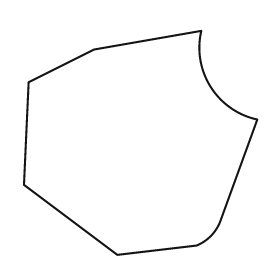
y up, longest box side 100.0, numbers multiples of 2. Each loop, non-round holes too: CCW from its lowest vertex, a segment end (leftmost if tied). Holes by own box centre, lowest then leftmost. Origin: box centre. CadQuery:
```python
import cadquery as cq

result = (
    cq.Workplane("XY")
    .moveTo(-10.0, -48.0)
    .lineTo(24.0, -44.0)
    .threePointArc((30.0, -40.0), (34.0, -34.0))
    .lineTo(50.0, 10.0)
    .threePointArc((30.0, 24.0), (26.0, 48.0))
    .lineTo(-20.0, 40.0)
    .lineTo(-48.0, 26.0)
    .lineTo(-50.0, -18.0)
    .close()
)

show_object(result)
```